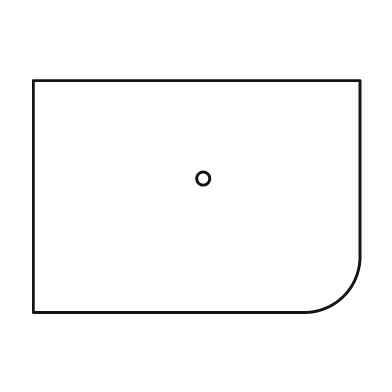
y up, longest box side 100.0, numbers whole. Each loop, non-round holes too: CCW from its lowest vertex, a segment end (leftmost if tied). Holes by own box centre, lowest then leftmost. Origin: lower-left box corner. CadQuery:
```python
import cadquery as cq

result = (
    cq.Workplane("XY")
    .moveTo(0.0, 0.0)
    .lineTo(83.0, 0.0)
    .threePointArc((95.0, 5.0), (100.0, 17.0))
    .lineTo(100.0, 71.0)
    .lineTo(0.0, 71.0)
    .close()
    .moveTo(52.0, 41.0)
    .circle(2.0)
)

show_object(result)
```